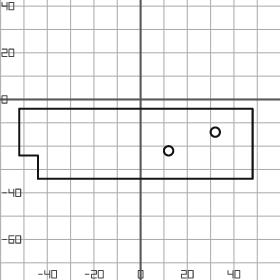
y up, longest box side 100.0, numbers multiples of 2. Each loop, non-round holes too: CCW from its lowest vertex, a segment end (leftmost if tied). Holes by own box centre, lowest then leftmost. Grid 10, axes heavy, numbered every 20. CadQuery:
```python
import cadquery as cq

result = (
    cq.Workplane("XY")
    .moveTo(-44.0, -34.0)
    .lineTo(48.0, -34.0)
    .lineTo(48.0, -4.0)
    .lineTo(-52.0, -4.0)
    .lineTo(-52.0, -24.0)
    .lineTo(-44.0, -24.0)
    .close()
    .moveTo(12.0, -22.0)
    .circle(2.0)
    .moveTo(32.0, -14.0)
    .circle(2.0)
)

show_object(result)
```